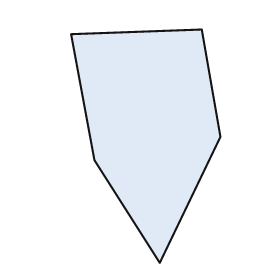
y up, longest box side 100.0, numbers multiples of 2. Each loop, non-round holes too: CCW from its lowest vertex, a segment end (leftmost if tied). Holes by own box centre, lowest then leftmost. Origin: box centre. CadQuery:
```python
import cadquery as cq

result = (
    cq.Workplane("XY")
    .moveTo(6.0, -50.0)
    .lineTo(32.0, 4.0)
    .lineTo(24.0, 50.0)
    .lineTo(-32.0, 48.0)
    .lineTo(-22.0, -6.0)
    .close()
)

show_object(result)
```